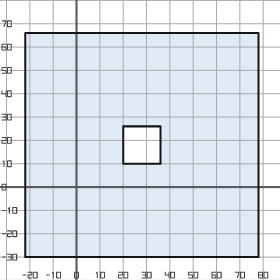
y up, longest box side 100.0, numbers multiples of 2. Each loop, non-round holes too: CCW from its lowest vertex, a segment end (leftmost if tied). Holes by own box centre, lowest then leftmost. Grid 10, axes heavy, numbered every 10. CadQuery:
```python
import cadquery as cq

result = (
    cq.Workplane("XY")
    .moveTo(-22.0, -30.0)
    .lineTo(78.0, -30.0)
    .lineTo(78.0, 66.0)
    .lineTo(-22.0, 66.0)
    .close()
    .moveTo(20.0, 10.0)
    .lineTo(36.0, 10.0)
    .lineTo(36.0, 26.0)
    .lineTo(20.0, 26.0)
    .close()
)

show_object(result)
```